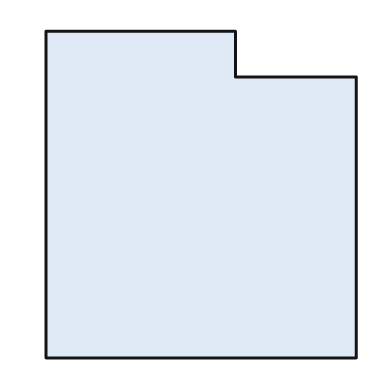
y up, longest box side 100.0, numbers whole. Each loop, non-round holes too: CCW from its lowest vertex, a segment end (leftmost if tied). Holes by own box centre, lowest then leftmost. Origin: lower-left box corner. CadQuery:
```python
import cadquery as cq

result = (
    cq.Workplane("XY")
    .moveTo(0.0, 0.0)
    .lineTo(95.0, 0.0)
    .lineTo(95.0, 86.0)
    .lineTo(58.0, 86.0)
    .lineTo(58.0, 100.0)
    .lineTo(0.0, 100.0)
    .close()
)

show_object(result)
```